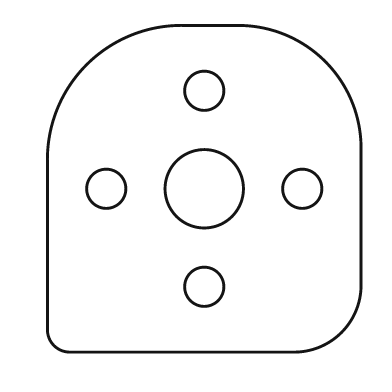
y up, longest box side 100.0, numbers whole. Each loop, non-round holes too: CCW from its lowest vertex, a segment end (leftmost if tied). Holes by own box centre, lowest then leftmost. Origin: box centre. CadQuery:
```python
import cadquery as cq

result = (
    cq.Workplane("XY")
    .moveTo(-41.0, -50.0)
    .lineTo(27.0, -50.0)
    .threePointArc((42.0, -44.0), (48.0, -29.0))
    .lineTo(48.0, 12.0)
    .threePointArc((37.0, 39.0), (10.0, 50.0))
    .lineTo(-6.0, 50.0)
    .threePointArc((-36.0, 38.0), (-48.0, 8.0))
    .lineTo(-48.0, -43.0)
    .threePointArc((-46.0, -48.0), (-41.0, -50.0))
    .close()
    .moveTo(0.0, -30.0)
    .circle(6.0)
    .moveTo(-30.0, 0.0)
    .circle(6.0)
    .moveTo(0.0, 0.0)
    .circle(12.0)
    .moveTo(30.0, 0.0)
    .circle(6.0)
    .moveTo(0.0, 30.0)
    .circle(6.0)
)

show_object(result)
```